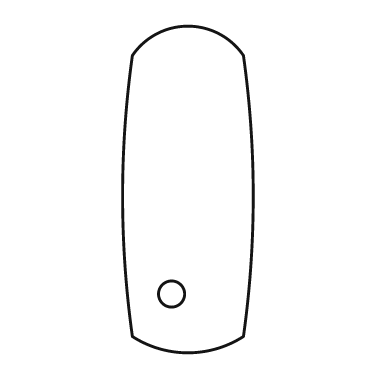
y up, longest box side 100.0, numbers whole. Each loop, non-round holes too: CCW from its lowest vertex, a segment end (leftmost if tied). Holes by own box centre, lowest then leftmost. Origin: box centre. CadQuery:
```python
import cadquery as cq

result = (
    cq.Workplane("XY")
    .moveTo(-17.0, -45.0)
    .threePointArc((0.0, -50.0), (17.0, -45.0))
    .threePointArc((20.0, -2.0), (17.0, 41.0))
    .threePointArc((0.0, 50.0), (-17.0, 41.0))
    .threePointArc((-20.0, -2.0), (-17.0, -45.0))
    .close()
    .moveTo(-5.0, -32.0)
    .circle(4.0)
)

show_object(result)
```